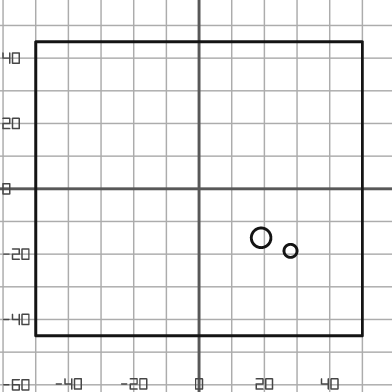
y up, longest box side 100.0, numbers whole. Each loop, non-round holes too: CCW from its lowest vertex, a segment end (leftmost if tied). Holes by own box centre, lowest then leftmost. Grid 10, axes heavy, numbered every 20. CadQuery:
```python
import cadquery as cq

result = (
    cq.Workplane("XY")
    .moveTo(-50.0, -45.0)
    .lineTo(50.0, -45.0)
    .lineTo(50.0, 45.0)
    .lineTo(-50.0, 45.0)
    .close()
    .moveTo(28.0, -19.0)
    .circle(2.0)
    .moveTo(19.0, -15.0)
    .circle(3.0)
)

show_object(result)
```